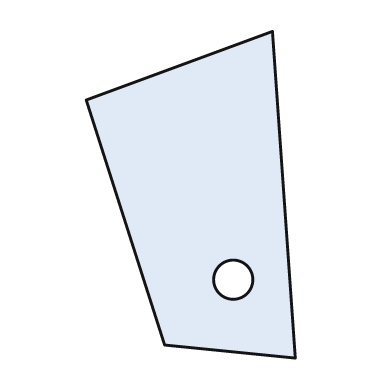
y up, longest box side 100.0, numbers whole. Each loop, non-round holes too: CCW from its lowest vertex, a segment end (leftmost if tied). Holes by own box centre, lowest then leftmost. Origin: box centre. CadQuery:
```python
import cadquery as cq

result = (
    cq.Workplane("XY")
    .moveTo(32.0, -50.0)
    .lineTo(25.0, 50.0)
    .lineTo(-32.0, 29.0)
    .lineTo(-8.0, -46.0)
    .close()
    .moveTo(13.0, -26.0)
    .circle(6.0)
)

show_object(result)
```